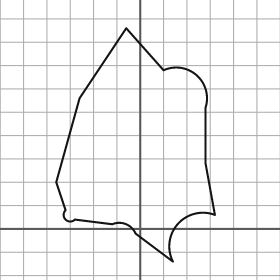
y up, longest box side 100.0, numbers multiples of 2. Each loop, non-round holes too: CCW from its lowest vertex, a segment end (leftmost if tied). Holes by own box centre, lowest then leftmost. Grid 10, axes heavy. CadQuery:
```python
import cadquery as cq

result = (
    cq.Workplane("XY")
    .moveTo(14.0, -14.0)
    .threePointArc((16.0, 2.0), (32.0, 6.0))
    .lineTo(28.0, 28.0)
    .lineTo(28.0, 52.0)
    .threePointArc((24.0, 66.0), (10.0, 68.0))
    .lineTo(-6.0, 86.0)
    .lineTo(-26.0, 56.0)
    .lineTo(-36.0, 20.0)
    .lineTo(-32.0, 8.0)
    .threePointArc((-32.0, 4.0), (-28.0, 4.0))
    .lineTo(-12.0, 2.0)
    .threePointArc((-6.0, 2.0), (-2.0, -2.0))
    .close()
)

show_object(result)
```